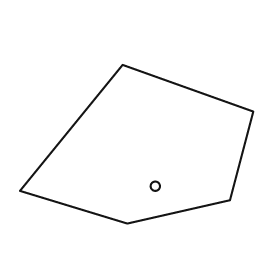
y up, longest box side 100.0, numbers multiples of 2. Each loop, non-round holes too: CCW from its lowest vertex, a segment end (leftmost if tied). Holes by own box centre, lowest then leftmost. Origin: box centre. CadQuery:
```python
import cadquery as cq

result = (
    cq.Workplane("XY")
    .moveTo(-4.0, -34.0)
    .lineTo(40.0, -24.0)
    .lineTo(50.0, 14.0)
    .lineTo(-6.0, 34.0)
    .lineTo(-50.0, -20.0)
    .close()
    .moveTo(8.0, -18.0)
    .circle(2.0)
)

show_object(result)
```